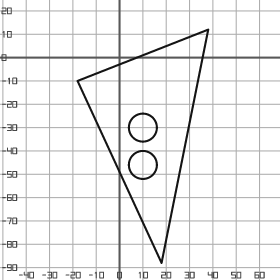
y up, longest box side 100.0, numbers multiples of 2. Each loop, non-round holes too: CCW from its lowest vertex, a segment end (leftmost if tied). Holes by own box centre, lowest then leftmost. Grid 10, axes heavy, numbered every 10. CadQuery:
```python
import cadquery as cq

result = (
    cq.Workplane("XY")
    .moveTo(18.0, -88.0)
    .lineTo(38.0, 12.0)
    .lineTo(-18.0, -10.0)
    .close()
    .moveTo(10.0, -46.0)
    .circle(6.0)
    .moveTo(10.0, -30.0)
    .circle(6.0)
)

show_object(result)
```